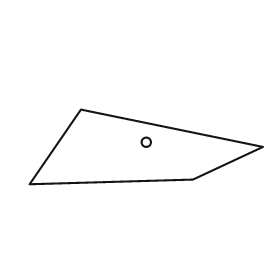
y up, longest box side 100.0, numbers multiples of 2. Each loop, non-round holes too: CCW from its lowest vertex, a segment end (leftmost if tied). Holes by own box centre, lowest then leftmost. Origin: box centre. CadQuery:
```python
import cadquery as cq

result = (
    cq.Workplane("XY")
    .moveTo(-50.0, -16.0)
    .lineTo(20.0, -14.0)
    .lineTo(50.0, 0.0)
    .lineTo(-28.0, 16.0)
    .close()
    .moveTo(0.0, 2.0)
    .circle(2.0)
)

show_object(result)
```